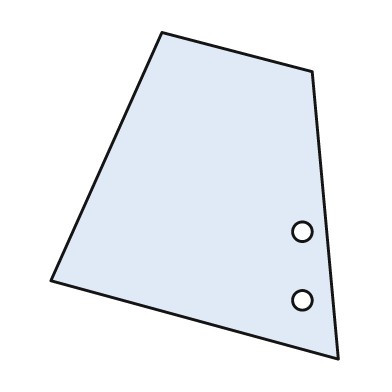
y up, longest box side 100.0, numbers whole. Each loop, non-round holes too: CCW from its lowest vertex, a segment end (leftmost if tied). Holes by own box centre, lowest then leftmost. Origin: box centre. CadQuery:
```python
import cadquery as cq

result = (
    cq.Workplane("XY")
    .moveTo(44.0, -50.0)
    .lineTo(36.0, 38.0)
    .lineTo(-10.0, 50.0)
    .lineTo(-44.0, -26.0)
    .close()
    .moveTo(33.0, -32.0)
    .circle(3.0)
    .moveTo(33.0, -11.0)
    .circle(3.0)
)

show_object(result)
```